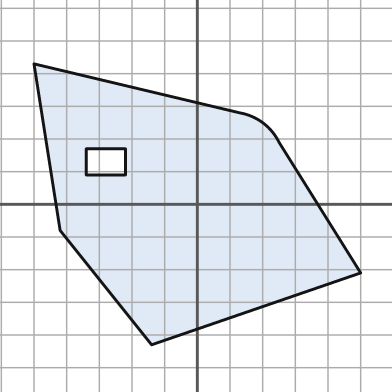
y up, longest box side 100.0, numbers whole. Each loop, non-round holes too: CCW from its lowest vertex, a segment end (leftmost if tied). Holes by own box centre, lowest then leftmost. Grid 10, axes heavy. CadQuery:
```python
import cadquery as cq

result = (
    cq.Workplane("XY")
    .moveTo(-14.0, -43.0)
    .lineTo(50.0, -21.0)
    .lineTo(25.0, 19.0)
    .threePointArc((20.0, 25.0), (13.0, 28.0))
    .lineTo(-50.0, 43.0)
    .lineTo(-42.0, -8.0)
    .close()
    .moveTo(-34.0, 9.0)
    .lineTo(-22.0, 9.0)
    .lineTo(-22.0, 17.0)
    .lineTo(-34.0, 17.0)
    .close()
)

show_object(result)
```